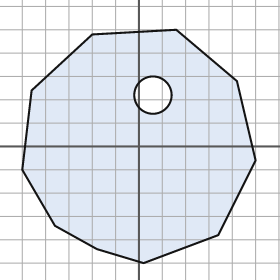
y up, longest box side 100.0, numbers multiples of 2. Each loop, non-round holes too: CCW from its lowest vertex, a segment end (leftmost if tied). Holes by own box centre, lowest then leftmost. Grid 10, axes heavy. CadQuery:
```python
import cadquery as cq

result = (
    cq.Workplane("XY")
    .moveTo(2.0, -50.0)
    .lineTo(34.0, -38.0)
    .lineTo(50.0, -6.0)
    .lineTo(42.0, 28.0)
    .lineTo(16.0, 50.0)
    .lineTo(-20.0, 48.0)
    .lineTo(-46.0, 24.0)
    .lineTo(-50.0, -10.0)
    .lineTo(-36.0, -34.0)
    .lineTo(-18.0, -44.0)
    .close()
    .moveTo(6.0, 22.0)
    .circle(8.0)
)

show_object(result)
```